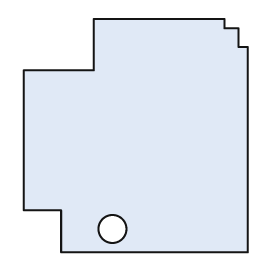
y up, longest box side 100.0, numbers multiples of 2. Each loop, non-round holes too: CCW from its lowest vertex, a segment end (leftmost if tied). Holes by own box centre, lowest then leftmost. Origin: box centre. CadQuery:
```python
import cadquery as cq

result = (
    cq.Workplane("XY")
    .moveTo(-32.0, -50.0)
    .lineTo(48.0, -50.0)
    .lineTo(48.0, 38.0)
    .lineTo(44.0, 38.0)
    .lineTo(44.0, 46.0)
    .lineTo(38.0, 46.0)
    .lineTo(38.0, 50.0)
    .lineTo(-18.0, 50.0)
    .lineTo(-18.0, 28.0)
    .lineTo(-48.0, 28.0)
    .lineTo(-48.0, -32.0)
    .lineTo(-32.0, -32.0)
    .close()
    .moveTo(-10.0, -40.0)
    .circle(6.0)
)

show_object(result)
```